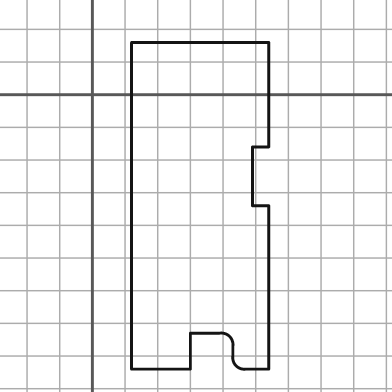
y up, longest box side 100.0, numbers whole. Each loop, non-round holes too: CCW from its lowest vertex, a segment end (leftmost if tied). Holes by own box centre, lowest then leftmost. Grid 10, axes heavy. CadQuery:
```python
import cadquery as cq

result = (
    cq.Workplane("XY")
    .moveTo(12.0, -84.0)
    .lineTo(30.0, -84.0)
    .lineTo(30.0, -73.0)
    .lineTo(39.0, -73.0)
    .threePointArc((42.0, -74.0), (43.0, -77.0))
    .lineTo(43.0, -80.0)
    .threePointArc((44.0, -83.0), (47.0, -84.0))
    .lineTo(54.0, -84.0)
    .lineTo(54.0, -34.0)
    .lineTo(49.0, -34.0)
    .lineTo(49.0, -16.0)
    .lineTo(54.0, -16.0)
    .lineTo(54.0, 16.0)
    .lineTo(12.0, 16.0)
    .close()
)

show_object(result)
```